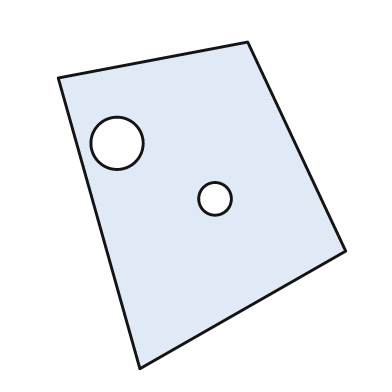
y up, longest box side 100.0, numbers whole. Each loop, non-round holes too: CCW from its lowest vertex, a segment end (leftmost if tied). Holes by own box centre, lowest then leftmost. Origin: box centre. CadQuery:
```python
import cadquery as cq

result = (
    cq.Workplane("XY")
    .moveTo(-19.0, -50.0)
    .lineTo(44.0, -14.0)
    .lineTo(14.0, 50.0)
    .lineTo(-44.0, 39.0)
    .close()
    .moveTo(4.0, 2.0)
    .circle(5.0)
    .moveTo(-26.0, 19.0)
    .circle(8.0)
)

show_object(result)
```